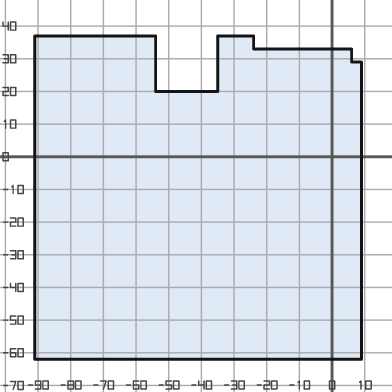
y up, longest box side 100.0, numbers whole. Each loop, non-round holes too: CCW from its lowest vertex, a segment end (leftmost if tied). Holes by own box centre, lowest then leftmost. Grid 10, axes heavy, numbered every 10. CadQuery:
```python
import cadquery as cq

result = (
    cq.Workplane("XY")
    .moveTo(-91.0, -62.0)
    .lineTo(9.0, -62.0)
    .lineTo(9.0, 29.0)
    .lineTo(6.0, 29.0)
    .lineTo(6.0, 33.0)
    .lineTo(-24.0, 33.0)
    .lineTo(-24.0, 37.0)
    .lineTo(-35.0, 37.0)
    .lineTo(-35.0, 20.0)
    .lineTo(-54.0, 20.0)
    .lineTo(-54.0, 37.0)
    .lineTo(-91.0, 37.0)
    .close()
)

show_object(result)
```